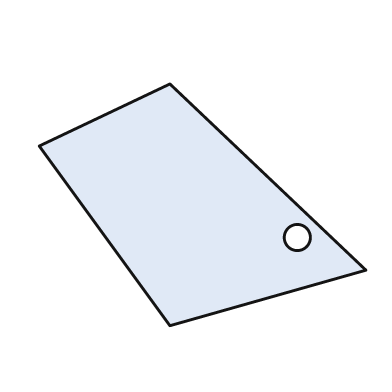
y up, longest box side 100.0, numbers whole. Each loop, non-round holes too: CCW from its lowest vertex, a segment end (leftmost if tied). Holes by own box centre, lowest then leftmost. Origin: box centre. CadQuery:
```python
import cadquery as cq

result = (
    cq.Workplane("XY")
    .moveTo(-10.0, -37.0)
    .lineTo(50.0, -20.0)
    .lineTo(-10.0, 37.0)
    .lineTo(-50.0, 18.0)
    .close()
    .moveTo(29.0, -10.0)
    .circle(4.0)
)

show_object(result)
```